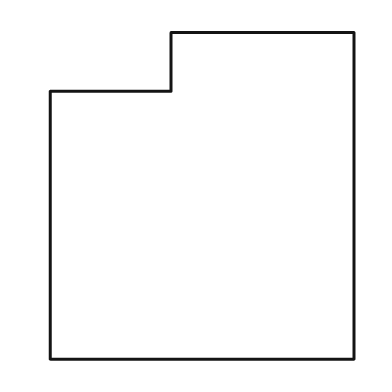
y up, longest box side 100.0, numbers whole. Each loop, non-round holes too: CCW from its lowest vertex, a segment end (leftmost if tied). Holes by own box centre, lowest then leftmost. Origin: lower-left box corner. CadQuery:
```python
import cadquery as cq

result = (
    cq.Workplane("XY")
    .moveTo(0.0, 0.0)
    .lineTo(93.0, 0.0)
    .lineTo(93.0, 100.0)
    .lineTo(37.0, 100.0)
    .lineTo(37.0, 82.0)
    .lineTo(0.0, 82.0)
    .close()
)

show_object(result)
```